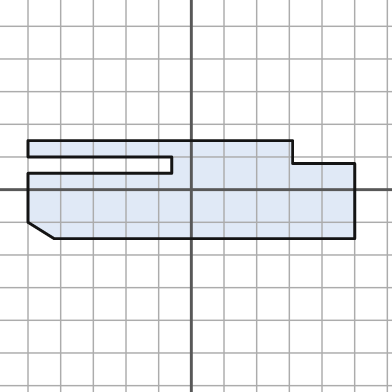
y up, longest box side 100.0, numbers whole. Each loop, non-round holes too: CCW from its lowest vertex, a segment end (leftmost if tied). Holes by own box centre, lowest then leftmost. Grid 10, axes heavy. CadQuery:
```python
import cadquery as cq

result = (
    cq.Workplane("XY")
    .moveTo(-42.0, -15.0)
    .lineTo(50.0, -15.0)
    .lineTo(50.0, 8.0)
    .lineTo(31.0, 8.0)
    .lineTo(31.0, 15.0)
    .lineTo(-50.0, 15.0)
    .lineTo(-50.0, 10.0)
    .lineTo(-6.0, 10.0)
    .lineTo(-6.0, 5.0)
    .lineTo(-50.0, 5.0)
    .lineTo(-50.0, -10.0)
    .close()
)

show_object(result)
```